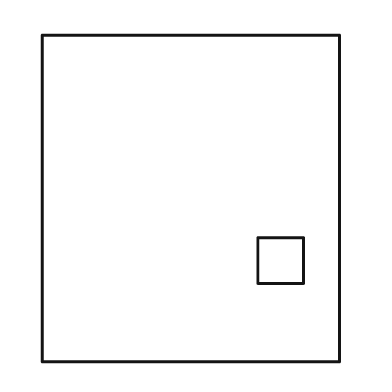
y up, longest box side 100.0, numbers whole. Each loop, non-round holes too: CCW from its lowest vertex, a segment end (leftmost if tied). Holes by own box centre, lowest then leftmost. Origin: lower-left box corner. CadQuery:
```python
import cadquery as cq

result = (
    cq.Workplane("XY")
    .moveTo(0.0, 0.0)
    .lineTo(91.0, 0.0)
    .lineTo(91.0, 100.0)
    .lineTo(0.0, 100.0)
    .close()
    .moveTo(66.0, 24.0)
    .lineTo(80.0, 24.0)
    .lineTo(80.0, 38.0)
    .lineTo(66.0, 38.0)
    .close()
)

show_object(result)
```